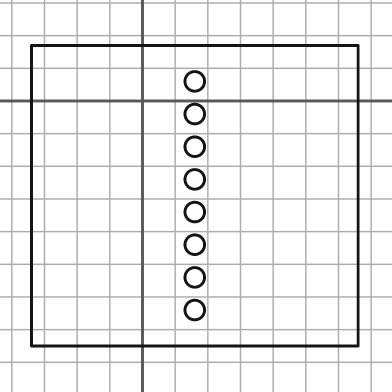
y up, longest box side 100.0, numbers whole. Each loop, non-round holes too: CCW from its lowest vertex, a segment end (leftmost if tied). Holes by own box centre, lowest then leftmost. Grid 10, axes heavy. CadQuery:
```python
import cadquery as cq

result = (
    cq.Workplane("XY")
    .moveTo(-34.0, -75.0)
    .lineTo(66.0, -75.0)
    .lineTo(66.0, 17.0)
    .lineTo(-34.0, 17.0)
    .close()
    .moveTo(16.0, -64.0)
    .circle(3.0)
    .moveTo(16.0, -54.0)
    .circle(3.0)
    .moveTo(16.0, -44.0)
    .circle(3.0)
    .moveTo(16.0, -34.0)
    .circle(3.0)
    .moveTo(16.0, -24.0)
    .circle(3.0)
    .moveTo(16.0, -14.0)
    .circle(3.0)
    .moveTo(16.0, -4.0)
    .circle(3.0)
    .moveTo(16.0, 6.0)
    .circle(3.0)
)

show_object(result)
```